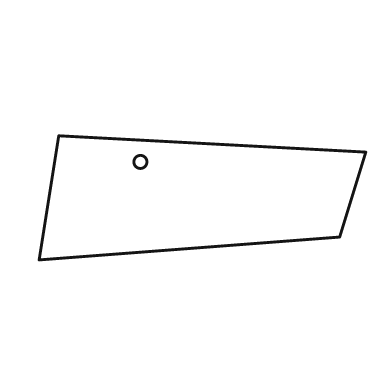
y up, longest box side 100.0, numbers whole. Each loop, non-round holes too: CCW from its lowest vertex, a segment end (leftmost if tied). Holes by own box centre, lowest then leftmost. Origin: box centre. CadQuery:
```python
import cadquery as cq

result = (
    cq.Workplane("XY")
    .moveTo(-50.0, -19.0)
    .lineTo(42.0, -12.0)
    .lineTo(50.0, 14.0)
    .lineTo(-44.0, 19.0)
    .close()
    .moveTo(-19.0, 11.0)
    .circle(2.0)
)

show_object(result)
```